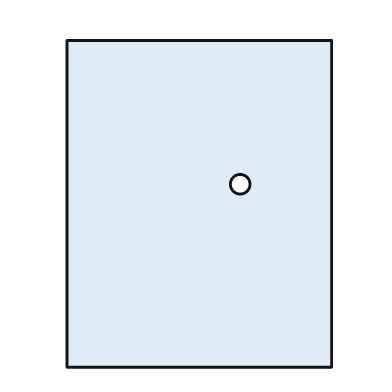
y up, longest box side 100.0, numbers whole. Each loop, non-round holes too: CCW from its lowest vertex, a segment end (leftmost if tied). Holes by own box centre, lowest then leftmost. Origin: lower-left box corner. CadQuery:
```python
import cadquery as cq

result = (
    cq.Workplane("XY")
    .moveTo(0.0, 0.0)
    .lineTo(81.0, 0.0)
    .lineTo(81.0, 100.0)
    .lineTo(0.0, 100.0)
    .close()
    .moveTo(53.0, 56.0)
    .circle(3.0)
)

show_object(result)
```